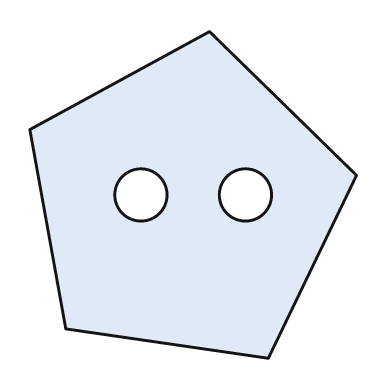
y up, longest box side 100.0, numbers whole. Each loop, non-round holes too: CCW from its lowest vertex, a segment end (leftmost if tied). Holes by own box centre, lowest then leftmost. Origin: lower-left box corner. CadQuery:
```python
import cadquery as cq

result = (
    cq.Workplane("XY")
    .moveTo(73.0, 0.0)
    .lineTo(100.0, 56.0)
    .lineTo(55.0, 100.0)
    .lineTo(0.0, 70.0)
    .lineTo(11.0, 9.0)
    .close()
    .moveTo(34.0, 50.0)
    .circle(8.0)
    .moveTo(66.0, 50.0)
    .circle(8.0)
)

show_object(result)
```